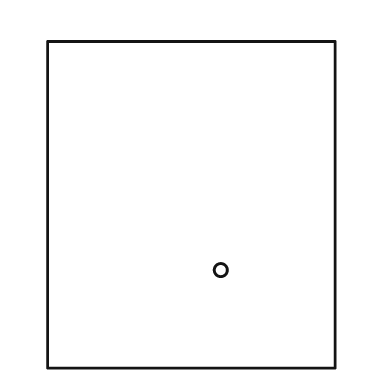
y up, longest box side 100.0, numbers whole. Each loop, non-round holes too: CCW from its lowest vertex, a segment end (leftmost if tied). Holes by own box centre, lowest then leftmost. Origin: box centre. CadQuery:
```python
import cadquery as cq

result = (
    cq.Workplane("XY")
    .moveTo(-44.0, -50.0)
    .lineTo(44.0, -50.0)
    .lineTo(44.0, 50.0)
    .lineTo(-44.0, 50.0)
    .close()
    .moveTo(9.0, -20.0)
    .circle(2.0)
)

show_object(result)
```